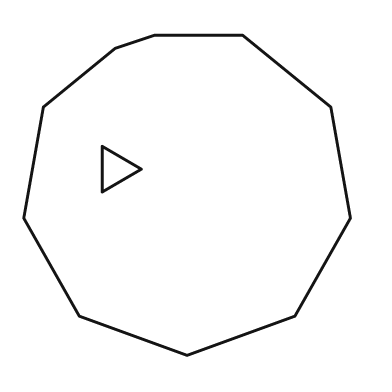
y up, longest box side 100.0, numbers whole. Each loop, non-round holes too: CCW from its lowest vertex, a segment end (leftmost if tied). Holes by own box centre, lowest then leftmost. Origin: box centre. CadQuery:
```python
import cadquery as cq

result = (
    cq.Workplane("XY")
    .moveTo(0.0, -49.0)
    .lineTo(33.0, -37.0)
    .lineTo(50.0, -7.0)
    .lineTo(44.0, 27.0)
    .lineTo(17.0, 49.0)
    .lineTo(-10.0, 49.0)
    .lineTo(-22.0, 45.0)
    .lineTo(-44.0, 27.0)
    .lineTo(-50.0, -7.0)
    .lineTo(-33.0, -37.0)
    .close()
    .moveTo(-26.0, 1.0)
    .lineTo(-14.0, 8.0)
    .lineTo(-26.0, 15.0)
    .close()
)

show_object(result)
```